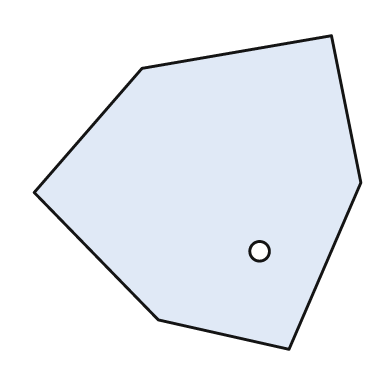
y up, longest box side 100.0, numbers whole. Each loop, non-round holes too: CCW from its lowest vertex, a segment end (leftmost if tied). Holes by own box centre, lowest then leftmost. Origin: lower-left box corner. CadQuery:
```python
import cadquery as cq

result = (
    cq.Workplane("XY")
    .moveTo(78.0, 0.0)
    .lineTo(100.0, 51.0)
    .lineTo(91.0, 96.0)
    .lineTo(33.0, 86.0)
    .lineTo(0.0, 48.0)
    .lineTo(38.0, 9.0)
    .close()
    .moveTo(69.0, 30.0)
    .circle(3.0)
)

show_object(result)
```